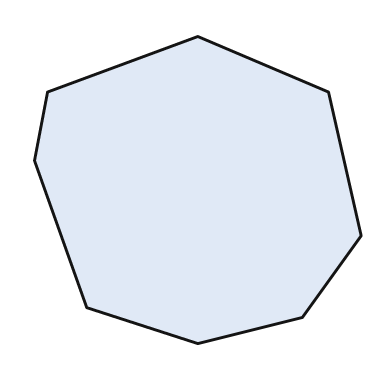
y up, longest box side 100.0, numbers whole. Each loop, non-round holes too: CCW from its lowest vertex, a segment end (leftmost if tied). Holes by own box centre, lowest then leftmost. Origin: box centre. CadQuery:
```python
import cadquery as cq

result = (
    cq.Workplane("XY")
    .moveTo(0.0, -47.0)
    .lineTo(32.0, -39.0)
    .lineTo(50.0, -14.0)
    .lineTo(40.0, 30.0)
    .lineTo(0.0, 47.0)
    .lineTo(-46.0, 30.0)
    .lineTo(-50.0, 9.0)
    .lineTo(-34.0, -36.0)
    .close()
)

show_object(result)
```